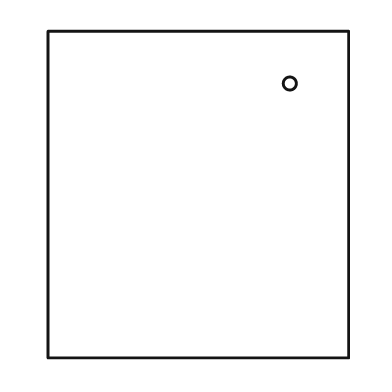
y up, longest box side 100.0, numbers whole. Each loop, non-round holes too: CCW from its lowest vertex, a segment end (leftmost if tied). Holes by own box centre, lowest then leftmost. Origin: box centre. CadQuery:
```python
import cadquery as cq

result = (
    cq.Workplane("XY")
    .moveTo(-46.0, -50.0)
    .lineTo(46.0, -50.0)
    .lineTo(46.0, 50.0)
    .lineTo(-46.0, 50.0)
    .close()
    .moveTo(28.0, 34.0)
    .circle(2.0)
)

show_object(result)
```